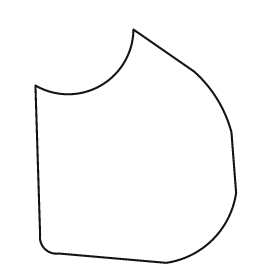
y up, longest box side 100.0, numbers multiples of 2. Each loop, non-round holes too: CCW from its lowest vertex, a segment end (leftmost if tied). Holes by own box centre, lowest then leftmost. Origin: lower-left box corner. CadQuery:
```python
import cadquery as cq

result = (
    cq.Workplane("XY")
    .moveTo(56.0, 0.0)
    .threePointArc((76.0, 10.0), (86.0, 30.0))
    .lineTo(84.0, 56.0)
    .threePointArc((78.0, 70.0), (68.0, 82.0))
    .lineTo(42.0, 100.0)
    .threePointArc((28.0, 76.0), (0.0, 76.0))
    .lineTo(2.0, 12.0)
    .threePointArc((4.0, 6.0), (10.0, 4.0))
    .close()
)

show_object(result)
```